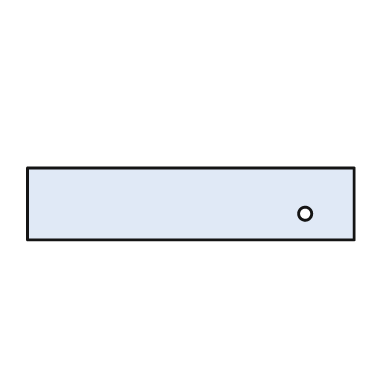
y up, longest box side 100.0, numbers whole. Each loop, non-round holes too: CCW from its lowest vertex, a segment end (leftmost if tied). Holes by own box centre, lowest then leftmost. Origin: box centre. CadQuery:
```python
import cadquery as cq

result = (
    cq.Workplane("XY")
    .moveTo(-50.0, -11.0)
    .lineTo(50.0, -11.0)
    .lineTo(50.0, 11.0)
    .lineTo(-50.0, 11.0)
    .close()
    .moveTo(35.0, -3.0)
    .circle(2.0)
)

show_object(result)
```